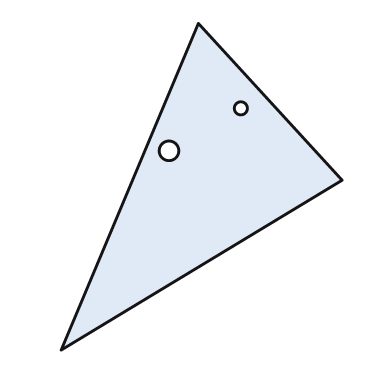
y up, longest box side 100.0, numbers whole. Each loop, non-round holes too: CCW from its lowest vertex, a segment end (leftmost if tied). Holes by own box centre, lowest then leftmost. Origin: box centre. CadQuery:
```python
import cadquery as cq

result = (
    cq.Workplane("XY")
    .moveTo(-43.0, -50.0)
    .lineTo(43.0, 2.0)
    .lineTo(-1.0, 50.0)
    .close()
    .moveTo(-10.0, 11.0)
    .circle(3.0)
    .moveTo(12.0, 24.0)
    .circle(2.0)
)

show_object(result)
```